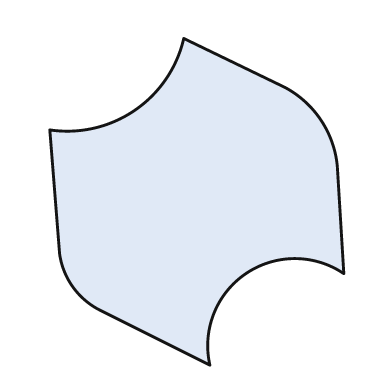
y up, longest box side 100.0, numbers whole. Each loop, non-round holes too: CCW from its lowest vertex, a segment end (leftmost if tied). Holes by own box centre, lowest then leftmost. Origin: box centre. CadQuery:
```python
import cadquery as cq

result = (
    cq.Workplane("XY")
    .moveTo(4.0, -50.0)
    .threePointArc((15.0, -22.0), (45.0, -22.0))
    .lineTo(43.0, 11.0)
    .threePointArc((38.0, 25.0), (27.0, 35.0))
    .lineTo(-4.0, 50.0)
    .threePointArc((-19.0, 28.0), (-45.0, 22.0))
    .lineTo(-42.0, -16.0)
    .threePointArc((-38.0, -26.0), (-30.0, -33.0))
    .close()
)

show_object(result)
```